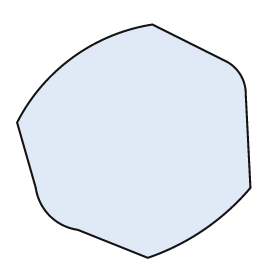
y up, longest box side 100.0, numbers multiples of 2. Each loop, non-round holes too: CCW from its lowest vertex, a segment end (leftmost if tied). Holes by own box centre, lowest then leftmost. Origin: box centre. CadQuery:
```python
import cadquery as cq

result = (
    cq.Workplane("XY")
    .moveTo(6.0, -50.0)
    .threePointArc((30.0, -38.0), (50.0, -20.0))
    .lineTo(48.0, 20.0)
    .threePointArc((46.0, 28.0), (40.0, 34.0))
    .lineTo(8.0, 50.0)
    .threePointArc((-26.0, 36.0), (-50.0, 8.0))
    .lineTo(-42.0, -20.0)
    .threePointArc((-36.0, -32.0), (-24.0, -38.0))
    .close()
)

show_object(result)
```